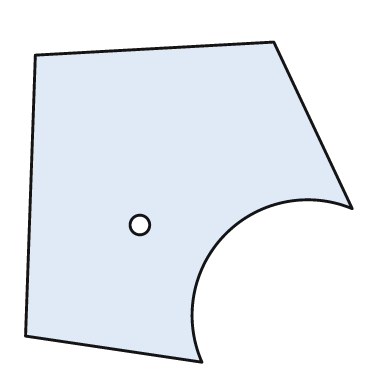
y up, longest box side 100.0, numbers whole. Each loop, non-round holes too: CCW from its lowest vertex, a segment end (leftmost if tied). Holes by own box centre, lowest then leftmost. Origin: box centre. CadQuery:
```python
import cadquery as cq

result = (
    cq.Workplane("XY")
    .moveTo(4.0, -49.0)
    .threePointArc((11.0, -10.0), (50.0, -2.0))
    .lineTo(26.0, 49.0)
    .lineTo(-47.0, 45.0)
    .lineTo(-50.0, -41.0)
    .close()
    .moveTo(-15.0, -7.0)
    .circle(3.0)
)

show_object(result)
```